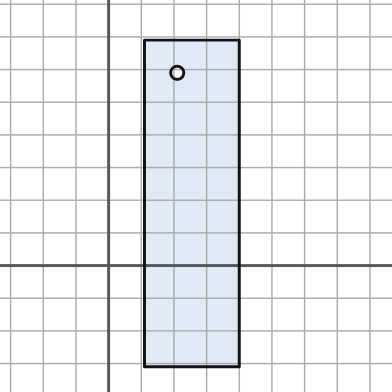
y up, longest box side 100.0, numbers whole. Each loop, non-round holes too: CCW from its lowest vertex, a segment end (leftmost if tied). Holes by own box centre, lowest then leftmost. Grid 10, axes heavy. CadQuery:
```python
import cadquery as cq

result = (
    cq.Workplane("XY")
    .moveTo(11.0, -31.0)
    .lineTo(40.0, -31.0)
    .lineTo(40.0, 69.0)
    .lineTo(11.0, 69.0)
    .close()
    .moveTo(21.0, 59.0)
    .circle(2.0)
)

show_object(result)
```